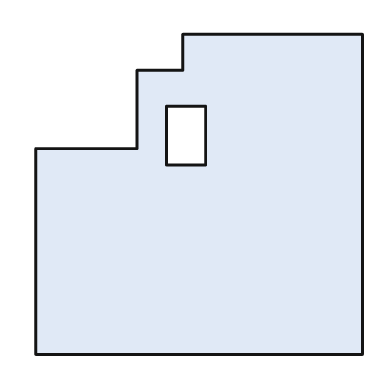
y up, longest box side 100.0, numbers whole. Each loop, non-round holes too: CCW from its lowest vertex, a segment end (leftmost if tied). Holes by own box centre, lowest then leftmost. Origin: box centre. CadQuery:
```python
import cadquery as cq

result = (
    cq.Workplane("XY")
    .moveTo(-50.0, -49.0)
    .lineTo(50.0, -49.0)
    .lineTo(50.0, 49.0)
    .lineTo(-5.0, 49.0)
    .lineTo(-5.0, 38.0)
    .lineTo(-19.0, 38.0)
    .lineTo(-19.0, 14.0)
    .lineTo(-50.0, 14.0)
    .close()
    .moveTo(-10.0, 9.0)
    .lineTo(2.0, 9.0)
    .lineTo(2.0, 27.0)
    .lineTo(-10.0, 27.0)
    .close()
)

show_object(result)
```